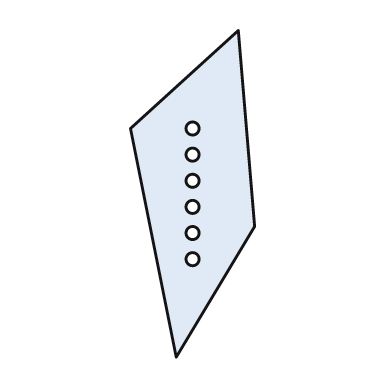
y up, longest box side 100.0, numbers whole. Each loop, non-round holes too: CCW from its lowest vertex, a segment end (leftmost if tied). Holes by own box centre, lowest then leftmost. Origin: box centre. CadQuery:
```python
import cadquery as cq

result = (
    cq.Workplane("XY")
    .moveTo(-5.0, -50.0)
    .lineTo(19.0, -10.0)
    .lineTo(14.0, 50.0)
    .lineTo(-19.0, 20.0)
    .close()
    .moveTo(0.0, -20.0)
    .circle(2.0)
    .moveTo(0.0, -12.0)
    .circle(2.0)
    .moveTo(0.0, -4.0)
    .circle(2.0)
    .moveTo(0.0, 4.0)
    .circle(2.0)
    .moveTo(0.0, 12.0)
    .circle(2.0)
    .moveTo(0.0, 20.0)
    .circle(2.0)
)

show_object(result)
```